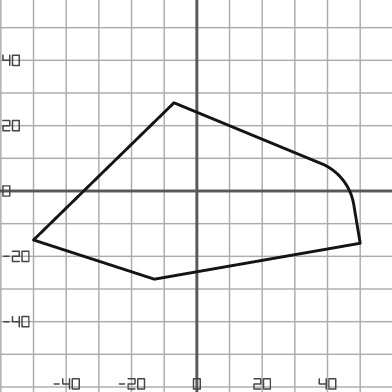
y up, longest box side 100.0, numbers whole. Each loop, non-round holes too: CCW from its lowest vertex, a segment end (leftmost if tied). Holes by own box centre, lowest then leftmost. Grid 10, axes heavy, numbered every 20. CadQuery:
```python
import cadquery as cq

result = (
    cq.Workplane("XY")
    .moveTo(-13.0, -27.0)
    .lineTo(50.0, -16.0)
    .lineTo(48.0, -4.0)
    .threePointArc((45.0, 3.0), (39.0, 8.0))
    .lineTo(-7.0, 27.0)
    .lineTo(-50.0, -15.0)
    .close()
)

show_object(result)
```